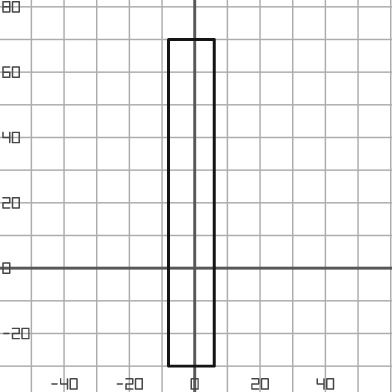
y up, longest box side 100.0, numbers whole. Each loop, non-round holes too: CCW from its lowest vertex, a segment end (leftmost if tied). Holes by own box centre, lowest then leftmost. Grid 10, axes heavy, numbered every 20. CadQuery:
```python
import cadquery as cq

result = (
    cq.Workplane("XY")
    .moveTo(-8.0, -30.0)
    .lineTo(6.0, -30.0)
    .lineTo(6.0, 70.0)
    .lineTo(-8.0, 70.0)
    .close()
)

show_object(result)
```